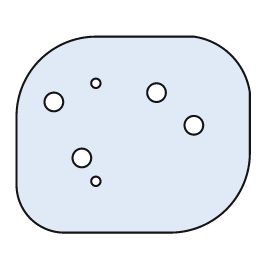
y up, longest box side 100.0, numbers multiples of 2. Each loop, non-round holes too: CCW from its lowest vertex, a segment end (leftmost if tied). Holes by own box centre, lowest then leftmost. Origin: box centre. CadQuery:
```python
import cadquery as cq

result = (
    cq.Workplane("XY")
    .moveTo(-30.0, -42.0)
    .lineTo(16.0, -42.0)
    .threePointArc((40.0, -32.0), (50.0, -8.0))
    .lineTo(50.0, 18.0)
    .threePointArc((42.0, 34.0), (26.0, 42.0))
    .lineTo(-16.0, 42.0)
    .threePointArc((-40.0, 32.0), (-50.0, 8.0))
    .lineTo(-50.0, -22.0)
    .threePointArc((-44.0, -36.0), (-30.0, -42.0))
    .close()
    .moveTo(-16.0, -20.0)
    .circle(2.0)
    .moveTo(-22.0, -10.0)
    .circle(4.0)
    .moveTo(26.0, 4.0)
    .circle(4.0)
    .moveTo(-34.0, 14.0)
    .circle(4.0)
    .moveTo(10.0, 18.0)
    .circle(4.0)
    .moveTo(-16.0, 22.0)
    .circle(2.0)
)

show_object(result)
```